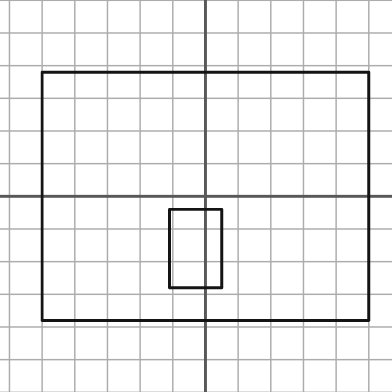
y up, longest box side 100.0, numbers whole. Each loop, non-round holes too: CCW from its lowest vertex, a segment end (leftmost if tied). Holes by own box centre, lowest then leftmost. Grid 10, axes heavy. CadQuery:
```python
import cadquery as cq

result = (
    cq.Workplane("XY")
    .moveTo(-50.0, -38.0)
    .lineTo(50.0, -38.0)
    .lineTo(50.0, 38.0)
    .lineTo(-50.0, 38.0)
    .close()
    .moveTo(-11.0, -28.0)
    .lineTo(5.0, -28.0)
    .lineTo(5.0, -4.0)
    .lineTo(-11.0, -4.0)
    .close()
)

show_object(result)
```